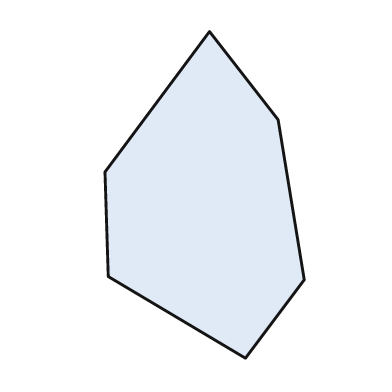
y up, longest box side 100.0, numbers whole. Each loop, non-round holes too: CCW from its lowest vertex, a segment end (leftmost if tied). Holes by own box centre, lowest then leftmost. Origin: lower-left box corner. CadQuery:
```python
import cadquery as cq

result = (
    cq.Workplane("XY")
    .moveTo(43.0, 0.0)
    .lineTo(61.0, 24.0)
    .lineTo(53.0, 73.0)
    .lineTo(32.0, 100.0)
    .lineTo(0.0, 57.0)
    .lineTo(1.0, 25.0)
    .close()
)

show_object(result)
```